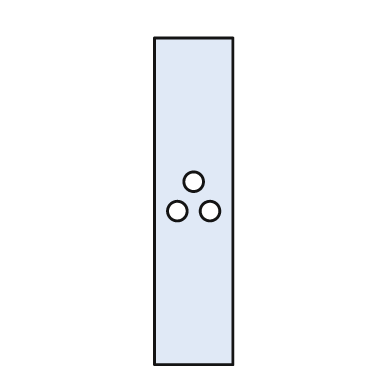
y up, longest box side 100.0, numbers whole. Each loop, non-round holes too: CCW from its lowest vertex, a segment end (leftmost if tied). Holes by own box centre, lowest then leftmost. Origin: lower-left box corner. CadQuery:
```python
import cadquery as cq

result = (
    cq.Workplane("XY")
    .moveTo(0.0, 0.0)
    .lineTo(24.0, 0.0)
    .lineTo(24.0, 100.0)
    .lineTo(0.0, 100.0)
    .close()
    .moveTo(7.0, 47.0)
    .circle(3.0)
    .moveTo(17.0, 47.0)
    .circle(3.0)
    .moveTo(12.0, 56.0)
    .circle(3.0)
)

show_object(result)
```